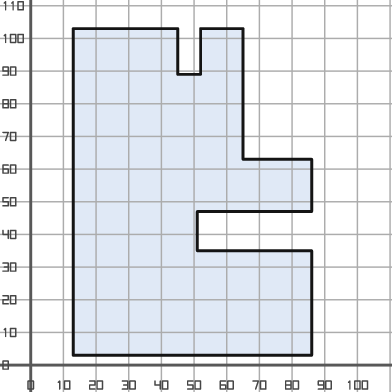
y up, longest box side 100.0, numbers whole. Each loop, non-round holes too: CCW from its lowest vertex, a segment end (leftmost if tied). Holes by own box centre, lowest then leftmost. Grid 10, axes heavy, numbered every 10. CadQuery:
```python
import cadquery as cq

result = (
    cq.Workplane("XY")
    .moveTo(13.0, 3.0)
    .lineTo(86.0, 3.0)
    .lineTo(86.0, 35.0)
    .lineTo(51.0, 35.0)
    .lineTo(51.0, 47.0)
    .lineTo(86.0, 47.0)
    .lineTo(86.0, 63.0)
    .lineTo(65.0, 63.0)
    .lineTo(65.0, 103.0)
    .lineTo(52.0, 103.0)
    .lineTo(52.0, 89.0)
    .lineTo(45.0, 89.0)
    .lineTo(45.0, 103.0)
    .lineTo(13.0, 103.0)
    .close()
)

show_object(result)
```